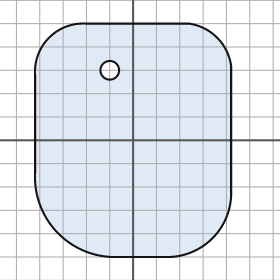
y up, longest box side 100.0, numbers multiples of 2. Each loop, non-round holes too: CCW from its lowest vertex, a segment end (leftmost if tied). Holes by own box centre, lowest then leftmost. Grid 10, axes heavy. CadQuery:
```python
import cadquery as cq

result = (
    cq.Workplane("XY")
    .moveTo(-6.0, -50.0)
    .lineTo(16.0, -50.0)
    .threePointArc((34.0, -42.0), (42.0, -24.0))
    .lineTo(42.0, 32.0)
    .threePointArc((36.0, 44.0), (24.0, 50.0))
    .lineTo(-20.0, 50.0)
    .threePointArc((-36.0, 44.0), (-42.0, 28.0))
    .lineTo(-42.0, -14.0)
    .threePointArc((-32.0, -40.0), (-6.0, -50.0))
    .close()
    .moveTo(-10.0, 30.0)
    .circle(4.0)
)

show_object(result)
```